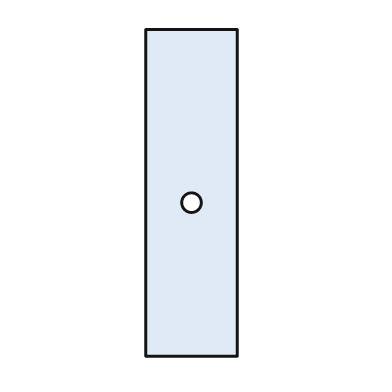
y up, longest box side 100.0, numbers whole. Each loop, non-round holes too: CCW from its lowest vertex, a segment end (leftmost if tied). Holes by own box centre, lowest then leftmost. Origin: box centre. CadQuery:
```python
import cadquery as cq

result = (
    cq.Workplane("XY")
    .moveTo(-14.0, -50.0)
    .lineTo(14.0, -50.0)
    .lineTo(14.0, 50.0)
    .lineTo(-14.0, 50.0)
    .close()
    .moveTo(0.0, -3.0)
    .circle(3.0)
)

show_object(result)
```